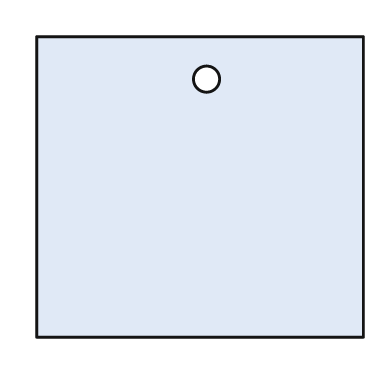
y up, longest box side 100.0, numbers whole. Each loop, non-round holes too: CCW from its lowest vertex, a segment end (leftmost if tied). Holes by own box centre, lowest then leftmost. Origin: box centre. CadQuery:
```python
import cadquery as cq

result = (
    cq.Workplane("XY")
    .moveTo(-50.0, -46.0)
    .lineTo(50.0, -46.0)
    .lineTo(50.0, 46.0)
    .lineTo(-50.0, 46.0)
    .close()
    .moveTo(2.0, 33.0)
    .circle(4.0)
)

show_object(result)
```